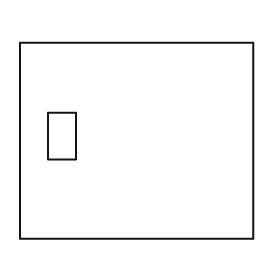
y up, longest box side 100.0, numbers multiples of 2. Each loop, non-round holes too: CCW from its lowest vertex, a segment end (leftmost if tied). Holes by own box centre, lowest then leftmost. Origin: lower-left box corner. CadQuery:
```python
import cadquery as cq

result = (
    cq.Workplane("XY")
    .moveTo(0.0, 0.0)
    .lineTo(100.0, 0.0)
    .lineTo(100.0, 84.0)
    .lineTo(0.0, 84.0)
    .close()
    .moveTo(12.0, 34.0)
    .lineTo(24.0, 34.0)
    .lineTo(24.0, 54.0)
    .lineTo(12.0, 54.0)
    .close()
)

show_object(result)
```